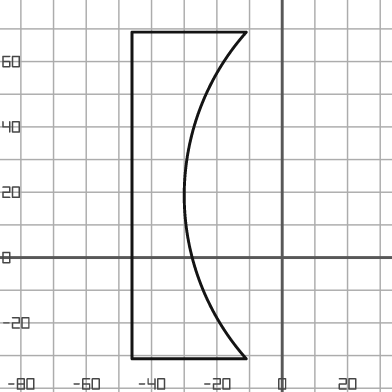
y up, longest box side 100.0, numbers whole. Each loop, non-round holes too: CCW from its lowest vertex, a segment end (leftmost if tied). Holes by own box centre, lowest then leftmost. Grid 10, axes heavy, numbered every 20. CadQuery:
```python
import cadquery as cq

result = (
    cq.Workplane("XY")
    .moveTo(-46.0, -31.0)
    .lineTo(-11.0, -31.0)
    .threePointArc((-30.0, 19.0), (-11.0, 69.0))
    .lineTo(-46.0, 69.0)
    .close()
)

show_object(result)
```